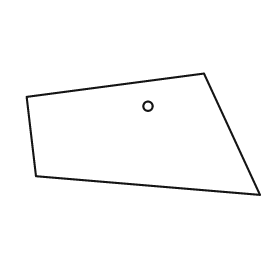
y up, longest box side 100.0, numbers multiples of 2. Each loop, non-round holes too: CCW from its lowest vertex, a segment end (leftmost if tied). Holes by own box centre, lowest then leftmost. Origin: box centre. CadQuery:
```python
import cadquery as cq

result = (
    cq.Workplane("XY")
    .moveTo(50.0, -26.0)
    .lineTo(26.0, 26.0)
    .lineTo(-50.0, 16.0)
    .lineTo(-46.0, -18.0)
    .close()
    .moveTo(2.0, 12.0)
    .circle(2.0)
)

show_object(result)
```